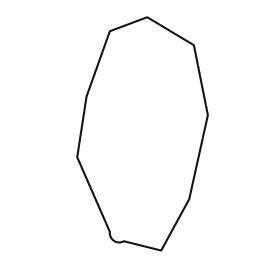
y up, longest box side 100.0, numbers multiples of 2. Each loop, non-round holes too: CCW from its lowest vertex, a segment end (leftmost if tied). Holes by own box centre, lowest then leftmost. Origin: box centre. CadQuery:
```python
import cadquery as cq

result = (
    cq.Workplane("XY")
    .moveTo(8.0, -50.0)
    .lineTo(20.0, -28.0)
    .lineTo(28.0, 8.0)
    .lineTo(22.0, 38.0)
    .lineTo(2.0, 50.0)
    .lineTo(-14.0, 44.0)
    .lineTo(-24.0, 16.0)
    .lineTo(-28.0, -10.0)
    .lineTo(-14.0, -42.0)
    .threePointArc((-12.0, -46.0), (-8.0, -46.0))
    .close()
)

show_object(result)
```